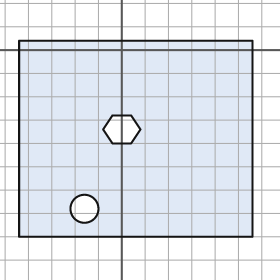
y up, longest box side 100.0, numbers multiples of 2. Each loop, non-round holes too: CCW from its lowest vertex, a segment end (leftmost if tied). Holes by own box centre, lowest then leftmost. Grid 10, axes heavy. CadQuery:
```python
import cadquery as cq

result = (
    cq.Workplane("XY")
    .moveTo(-44.0, -80.0)
    .lineTo(56.0, -80.0)
    .lineTo(56.0, 4.0)
    .lineTo(-44.0, 4.0)
    .close()
    .moveTo(-16.0, -68.0)
    .circle(6.0)
    .moveTo(-4.0, -40.0)
    .lineTo(4.0, -40.0)
    .lineTo(8.0, -34.0)
    .lineTo(4.0, -28.0)
    .lineTo(-4.0, -28.0)
    .lineTo(-8.0, -34.0)
    .close()
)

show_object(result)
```